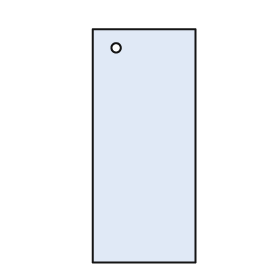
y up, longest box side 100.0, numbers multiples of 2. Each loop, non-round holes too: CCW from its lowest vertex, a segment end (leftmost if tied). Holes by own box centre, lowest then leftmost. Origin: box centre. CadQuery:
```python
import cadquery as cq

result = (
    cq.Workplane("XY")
    .moveTo(-22.0, -50.0)
    .lineTo(22.0, -50.0)
    .lineTo(22.0, 50.0)
    .lineTo(-22.0, 50.0)
    .close()
    .moveTo(-12.0, 42.0)
    .circle(2.0)
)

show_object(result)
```